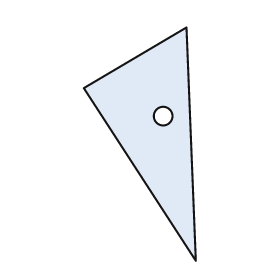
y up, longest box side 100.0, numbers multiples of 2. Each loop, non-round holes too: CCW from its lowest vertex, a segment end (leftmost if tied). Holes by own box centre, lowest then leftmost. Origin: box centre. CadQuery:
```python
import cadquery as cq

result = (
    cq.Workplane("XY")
    .moveTo(24.0, -50.0)
    .lineTo(20.0, 50.0)
    .lineTo(-24.0, 24.0)
    .close()
    .moveTo(10.0, 12.0)
    .circle(4.0)
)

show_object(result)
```